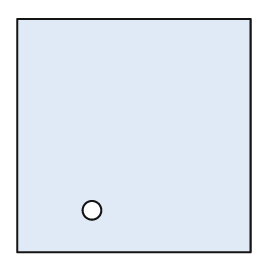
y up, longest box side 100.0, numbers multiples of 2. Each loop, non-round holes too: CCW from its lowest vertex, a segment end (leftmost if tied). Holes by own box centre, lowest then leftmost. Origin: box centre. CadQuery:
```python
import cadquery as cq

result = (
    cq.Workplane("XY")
    .moveTo(-50.0, -50.0)
    .lineTo(50.0, -50.0)
    .lineTo(50.0, 50.0)
    .lineTo(-50.0, 50.0)
    .close()
    .moveTo(-18.0, -32.0)
    .circle(4.0)
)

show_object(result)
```